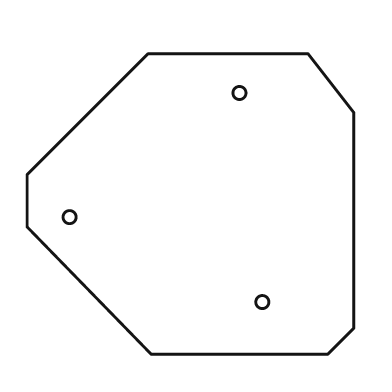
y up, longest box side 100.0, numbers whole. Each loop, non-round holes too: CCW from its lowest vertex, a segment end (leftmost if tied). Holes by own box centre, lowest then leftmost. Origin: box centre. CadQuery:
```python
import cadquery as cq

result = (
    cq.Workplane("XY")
    .moveTo(-12.0, -46.0)
    .lineTo(42.0, -46.0)
    .lineTo(50.0, -38.0)
    .lineTo(50.0, 28.0)
    .lineTo(36.0, 46.0)
    .lineTo(-13.0, 46.0)
    .lineTo(-50.0, 9.0)
    .lineTo(-50.0, -7.0)
    .close()
    .moveTo(22.0, -30.0)
    .circle(2.0)
    .moveTo(-37.0, -4.0)
    .circle(2.0)
    .moveTo(15.0, 34.0)
    .circle(2.0)
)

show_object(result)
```